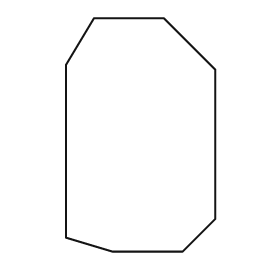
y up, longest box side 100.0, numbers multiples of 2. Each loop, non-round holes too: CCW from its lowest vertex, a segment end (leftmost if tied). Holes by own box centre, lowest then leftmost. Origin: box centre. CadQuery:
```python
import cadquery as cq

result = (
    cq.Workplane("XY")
    .moveTo(-12.0, -50.0)
    .lineTo(18.0, -50.0)
    .lineTo(32.0, -36.0)
    .lineTo(32.0, 28.0)
    .lineTo(10.0, 50.0)
    .lineTo(-20.0, 50.0)
    .lineTo(-32.0, 30.0)
    .lineTo(-32.0, -44.0)
    .close()
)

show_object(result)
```